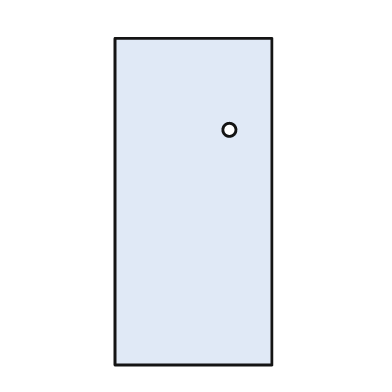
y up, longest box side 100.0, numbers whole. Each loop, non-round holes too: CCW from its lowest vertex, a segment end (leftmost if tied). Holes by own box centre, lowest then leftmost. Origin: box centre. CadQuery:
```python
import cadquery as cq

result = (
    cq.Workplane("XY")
    .moveTo(-24.0, -50.0)
    .lineTo(24.0, -50.0)
    .lineTo(24.0, 50.0)
    .lineTo(-24.0, 50.0)
    .close()
    .moveTo(11.0, 22.0)
    .circle(2.0)
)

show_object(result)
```